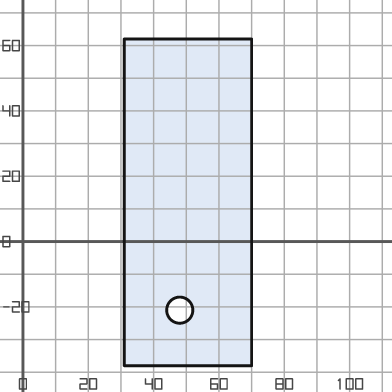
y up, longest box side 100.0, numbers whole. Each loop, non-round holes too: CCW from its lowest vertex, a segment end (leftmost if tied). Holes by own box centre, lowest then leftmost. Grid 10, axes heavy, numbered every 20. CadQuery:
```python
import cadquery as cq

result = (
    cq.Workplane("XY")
    .moveTo(31.0, -38.0)
    .lineTo(70.0, -38.0)
    .lineTo(70.0, 62.0)
    .lineTo(31.0, 62.0)
    .close()
    .moveTo(48.0, -21.0)
    .circle(4.0)
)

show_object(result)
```